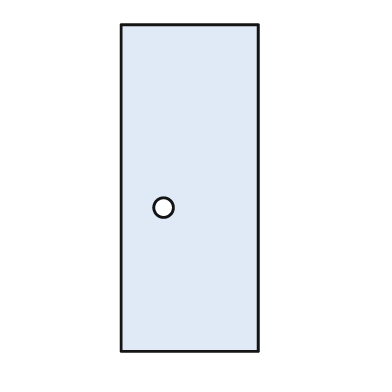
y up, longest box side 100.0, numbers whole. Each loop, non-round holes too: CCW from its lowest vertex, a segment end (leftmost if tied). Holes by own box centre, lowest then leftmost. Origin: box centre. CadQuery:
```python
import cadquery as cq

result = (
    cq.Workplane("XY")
    .moveTo(-21.0, -50.0)
    .lineTo(21.0, -50.0)
    .lineTo(21.0, 50.0)
    .lineTo(-21.0, 50.0)
    .close()
    .moveTo(-8.0, -6.0)
    .circle(3.0)
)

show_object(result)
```